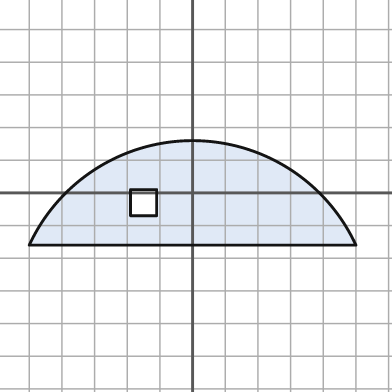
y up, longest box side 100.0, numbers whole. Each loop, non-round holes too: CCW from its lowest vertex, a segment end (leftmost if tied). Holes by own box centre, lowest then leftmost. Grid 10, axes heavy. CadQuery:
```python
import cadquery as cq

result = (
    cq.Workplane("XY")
    .moveTo(-50.0, -16.0)
    .lineTo(50.0, -16.0)
    .threePointArc((0.0, 16.0), (-50.0, -16.0))
    .close()
    .moveTo(-19.0, -7.0)
    .lineTo(-11.0, -7.0)
    .lineTo(-11.0, 1.0)
    .lineTo(-19.0, 1.0)
    .close()
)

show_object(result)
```